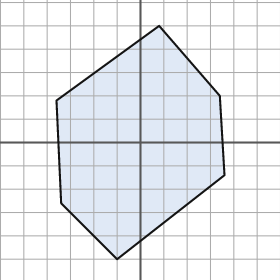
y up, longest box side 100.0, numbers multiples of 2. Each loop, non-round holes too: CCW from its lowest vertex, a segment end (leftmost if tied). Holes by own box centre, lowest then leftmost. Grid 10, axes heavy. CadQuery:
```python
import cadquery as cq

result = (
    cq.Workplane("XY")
    .moveTo(-10.0, -50.0)
    .lineTo(36.0, -14.0)
    .lineTo(34.0, 20.0)
    .lineTo(8.0, 50.0)
    .lineTo(-36.0, 18.0)
    .lineTo(-34.0, -26.0)
    .close()
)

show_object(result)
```